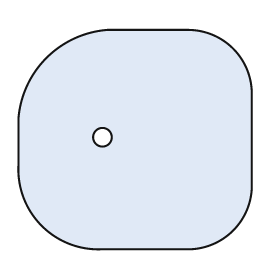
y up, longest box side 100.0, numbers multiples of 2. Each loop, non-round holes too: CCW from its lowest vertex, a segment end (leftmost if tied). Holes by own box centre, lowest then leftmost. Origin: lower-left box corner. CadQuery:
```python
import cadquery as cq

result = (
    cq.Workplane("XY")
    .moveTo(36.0, 0.0)
    .lineTo(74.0, 0.0)
    .threePointArc((92.0, 8.0), (100.0, 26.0))
    .lineTo(100.0, 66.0)
    .threePointArc((92.0, 86.0), (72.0, 94.0))
    .lineTo(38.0, 94.0)
    .threePointArc((12.0, 82.0), (0.0, 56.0))
    .lineTo(0.0, 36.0)
    .threePointArc((10.0, 10.0), (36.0, 0.0))
    .close()
    .moveTo(36.0, 48.0)
    .circle(4.0)
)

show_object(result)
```